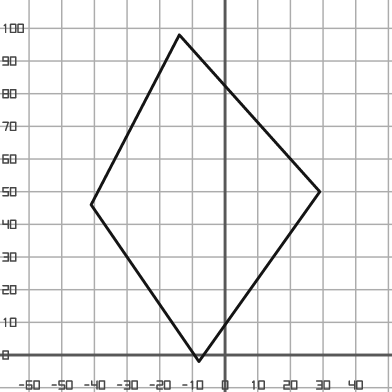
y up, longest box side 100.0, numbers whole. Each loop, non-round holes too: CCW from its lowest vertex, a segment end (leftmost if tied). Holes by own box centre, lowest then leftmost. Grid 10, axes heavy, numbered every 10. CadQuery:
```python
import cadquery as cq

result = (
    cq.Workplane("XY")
    .moveTo(-8.0, -2.0)
    .lineTo(29.0, 50.0)
    .lineTo(-14.0, 98.0)
    .lineTo(-41.0, 46.0)
    .close()
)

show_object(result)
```